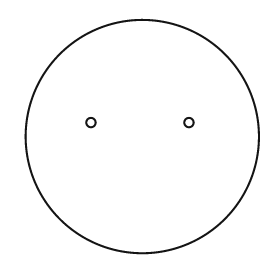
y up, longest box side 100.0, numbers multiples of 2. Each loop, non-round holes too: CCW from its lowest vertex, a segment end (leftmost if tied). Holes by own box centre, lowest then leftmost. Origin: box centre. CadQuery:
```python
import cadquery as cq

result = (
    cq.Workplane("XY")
    .moveTo(0.0, 0.0)
    .circle(50.0)
    .moveTo(-22.0, 6.0)
    .circle(2.0)
    .moveTo(20.0, 6.0)
    .circle(2.0)
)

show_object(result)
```